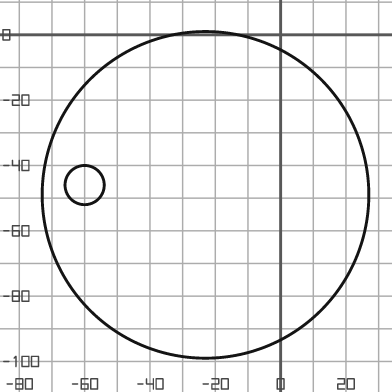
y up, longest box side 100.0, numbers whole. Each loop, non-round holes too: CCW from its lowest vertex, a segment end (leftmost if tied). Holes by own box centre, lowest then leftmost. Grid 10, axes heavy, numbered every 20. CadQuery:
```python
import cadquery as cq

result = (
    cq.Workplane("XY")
    .moveTo(-23.0, -49.0)
    .circle(50.0)
    .moveTo(-60.0, -46.0)
    .circle(6.0)
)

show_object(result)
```